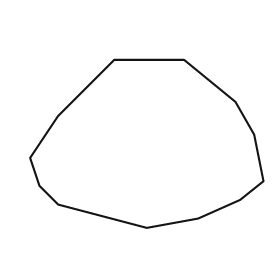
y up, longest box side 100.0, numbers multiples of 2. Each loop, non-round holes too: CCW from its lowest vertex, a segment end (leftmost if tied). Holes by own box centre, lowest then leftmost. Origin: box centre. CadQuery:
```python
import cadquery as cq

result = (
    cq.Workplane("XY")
    .moveTo(0.0, -36.0)
    .lineTo(22.0, -32.0)
    .lineTo(40.0, -24.0)
    .lineTo(50.0, -16.0)
    .lineTo(46.0, 4.0)
    .lineTo(38.0, 18.0)
    .lineTo(16.0, 36.0)
    .lineTo(-14.0, 36.0)
    .lineTo(-38.0, 12.0)
    .lineTo(-50.0, -6.0)
    .lineTo(-46.0, -18.0)
    .lineTo(-38.0, -26.0)
    .close()
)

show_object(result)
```